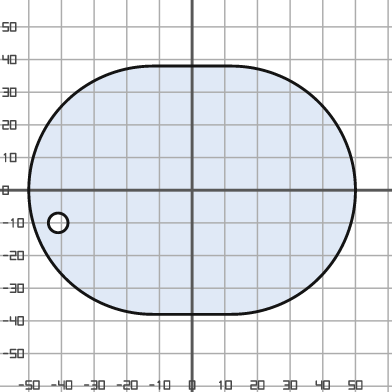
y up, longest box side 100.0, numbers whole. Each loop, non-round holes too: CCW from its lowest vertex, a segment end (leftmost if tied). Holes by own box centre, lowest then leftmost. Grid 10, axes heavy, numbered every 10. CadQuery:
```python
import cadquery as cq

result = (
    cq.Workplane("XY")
    .moveTo(-12.0, -38.0)
    .lineTo(12.0, -38.0)
    .threePointArc((50.0, 0.0), (12.0, 38.0))
    .lineTo(-12.0, 38.0)
    .threePointArc((-50.0, 0.0), (-12.0, -38.0))
    .close()
    .moveTo(-41.0, -10.0)
    .circle(3.0)
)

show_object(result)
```